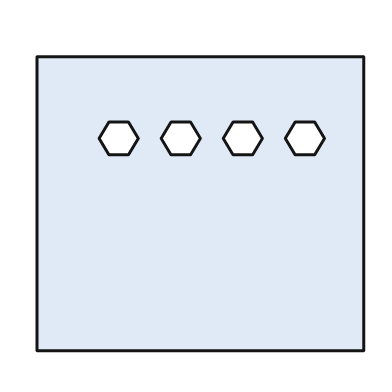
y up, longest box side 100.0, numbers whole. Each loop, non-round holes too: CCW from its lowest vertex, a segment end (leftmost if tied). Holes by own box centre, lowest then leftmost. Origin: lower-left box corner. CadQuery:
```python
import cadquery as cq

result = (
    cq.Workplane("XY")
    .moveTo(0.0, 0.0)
    .lineTo(100.0, 0.0)
    .lineTo(100.0, 90.0)
    .lineTo(0.0, 90.0)
    .close()
    .moveTo(22.0, 60.0)
    .lineTo(28.0, 60.0)
    .lineTo(31.0, 65.0)
    .lineTo(28.0, 70.0)
    .lineTo(22.0, 70.0)
    .lineTo(19.0, 65.0)
    .close()
    .moveTo(41.0, 60.0)
    .lineTo(47.0, 60.0)
    .lineTo(50.0, 65.0)
    .lineTo(47.0, 70.0)
    .lineTo(41.0, 70.0)
    .lineTo(38.0, 65.0)
    .close()
    .moveTo(60.0, 60.0)
    .lineTo(66.0, 60.0)
    .lineTo(69.0, 65.0)
    .lineTo(66.0, 70.0)
    .lineTo(60.0, 70.0)
    .lineTo(57.0, 65.0)
    .close()
    .moveTo(79.0, 60.0)
    .lineTo(85.0, 60.0)
    .lineTo(88.0, 65.0)
    .lineTo(85.0, 70.0)
    .lineTo(79.0, 70.0)
    .lineTo(76.0, 65.0)
    .close()
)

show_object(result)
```